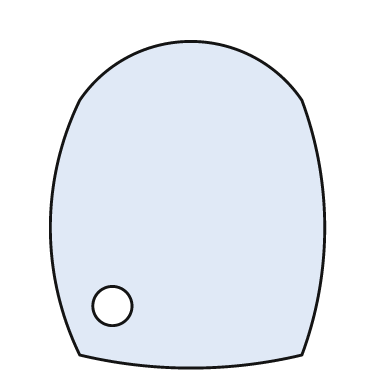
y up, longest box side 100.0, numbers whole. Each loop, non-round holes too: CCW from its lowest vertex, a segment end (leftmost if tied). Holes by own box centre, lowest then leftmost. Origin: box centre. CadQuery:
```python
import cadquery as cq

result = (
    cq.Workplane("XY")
    .moveTo(-33.0, -46.0)
    .threePointArc((1.0, -50.0), (35.0, -46.0))
    .threePointArc((42.0, -7.0), (35.0, 32.0))
    .threePointArc((1.0, 50.0), (-33.0, 32.0))
    .threePointArc((-42.0, -7.0), (-33.0, -46.0))
    .close()
    .moveTo(-23.0, -31.0)
    .circle(6.0)
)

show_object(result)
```